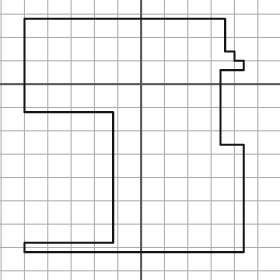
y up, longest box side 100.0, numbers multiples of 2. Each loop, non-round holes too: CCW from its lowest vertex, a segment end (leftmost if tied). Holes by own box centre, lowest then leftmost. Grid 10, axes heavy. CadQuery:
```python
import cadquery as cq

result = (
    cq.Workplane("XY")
    .moveTo(-50.0, -72.0)
    .lineTo(44.0, -72.0)
    .lineTo(44.0, -26.0)
    .lineTo(34.0, -26.0)
    .lineTo(34.0, 6.0)
    .lineTo(44.0, 6.0)
    .lineTo(44.0, 10.0)
    .lineTo(40.0, 10.0)
    .lineTo(40.0, 14.0)
    .lineTo(36.0, 14.0)
    .lineTo(36.0, 28.0)
    .lineTo(-50.0, 28.0)
    .lineTo(-50.0, -12.0)
    .lineTo(-12.0, -12.0)
    .lineTo(-12.0, -68.0)
    .lineTo(-50.0, -68.0)
    .close()
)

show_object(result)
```